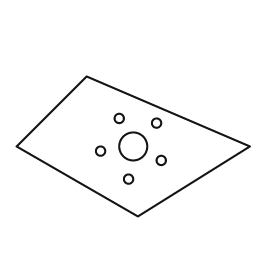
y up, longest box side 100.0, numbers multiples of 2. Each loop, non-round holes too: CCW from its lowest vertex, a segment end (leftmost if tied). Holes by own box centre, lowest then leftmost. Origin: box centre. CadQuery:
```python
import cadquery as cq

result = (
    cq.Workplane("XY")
    .moveTo(2.0, -30.0)
    .lineTo(50.0, 0.0)
    .lineTo(-20.0, 30.0)
    .lineTo(-50.0, 0.0)
    .close()
    .moveTo(-2.0, -14.0)
    .circle(2.0)
    .moveTo(12.0, -6.0)
    .circle(2.0)
    .moveTo(-14.0, -2.0)
    .circle(2.0)
    .moveTo(0.0, 0.0)
    .circle(6.0)
    .moveTo(10.0, 10.0)
    .circle(2.0)
    .moveTo(-6.0, 12.0)
    .circle(2.0)
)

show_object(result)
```